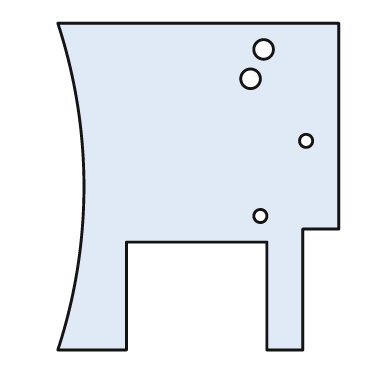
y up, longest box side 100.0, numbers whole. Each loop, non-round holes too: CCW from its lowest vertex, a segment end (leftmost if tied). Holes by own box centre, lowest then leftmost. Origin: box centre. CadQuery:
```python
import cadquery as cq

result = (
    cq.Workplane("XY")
    .moveTo(-43.0, -50.0)
    .lineTo(-22.0, -50.0)
    .lineTo(-22.0, -17.0)
    .lineTo(21.0, -17.0)
    .lineTo(21.0, -50.0)
    .lineTo(32.0, -50.0)
    .lineTo(32.0, -13.0)
    .lineTo(43.0, -13.0)
    .lineTo(43.0, 50.0)
    .lineTo(-43.0, 50.0)
    .threePointArc((-35.0, 0.0), (-43.0, -50.0))
    .close()
    .moveTo(19.0, -9.0)
    .circle(2.0)
    .moveTo(33.0, 14.0)
    .circle(2.0)
    .moveTo(16.0, 33.0)
    .circle(3.0)
    .moveTo(20.0, 42.0)
    .circle(3.0)
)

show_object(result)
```